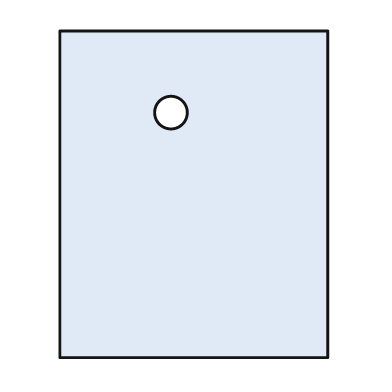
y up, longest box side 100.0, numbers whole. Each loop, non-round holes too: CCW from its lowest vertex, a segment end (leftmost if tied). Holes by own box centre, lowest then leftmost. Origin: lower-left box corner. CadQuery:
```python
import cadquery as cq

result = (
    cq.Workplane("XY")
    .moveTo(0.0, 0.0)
    .lineTo(82.0, 0.0)
    .lineTo(82.0, 100.0)
    .lineTo(0.0, 100.0)
    .close()
    .moveTo(34.0, 75.0)
    .circle(5.0)
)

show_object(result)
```